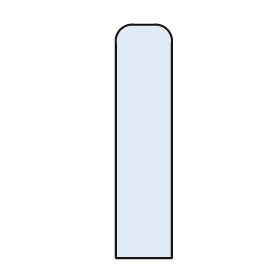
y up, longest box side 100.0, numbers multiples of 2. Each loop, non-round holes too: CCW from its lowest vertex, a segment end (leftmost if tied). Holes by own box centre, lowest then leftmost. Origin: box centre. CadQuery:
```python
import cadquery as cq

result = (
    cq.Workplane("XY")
    .moveTo(-12.0, -50.0)
    .lineTo(12.0, -50.0)
    .lineTo(12.0, 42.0)
    .threePointArc((10.0, 48.0), (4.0, 50.0))
    .lineTo(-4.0, 50.0)
    .threePointArc((-10.0, 48.0), (-12.0, 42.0))
    .close()
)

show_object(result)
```